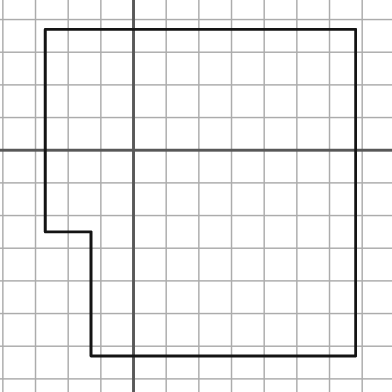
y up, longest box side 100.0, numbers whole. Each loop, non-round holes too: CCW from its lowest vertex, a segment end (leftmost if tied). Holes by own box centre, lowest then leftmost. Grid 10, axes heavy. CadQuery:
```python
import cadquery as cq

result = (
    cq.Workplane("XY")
    .moveTo(-13.0, -63.0)
    .lineTo(68.0, -63.0)
    .lineTo(68.0, 37.0)
    .lineTo(-27.0, 37.0)
    .lineTo(-27.0, -25.0)
    .lineTo(-13.0, -25.0)
    .close()
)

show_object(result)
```